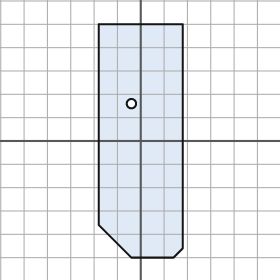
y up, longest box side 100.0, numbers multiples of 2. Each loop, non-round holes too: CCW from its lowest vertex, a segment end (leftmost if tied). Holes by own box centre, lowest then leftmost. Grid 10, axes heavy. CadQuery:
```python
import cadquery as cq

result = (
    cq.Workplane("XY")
    .moveTo(-4.0, -50.0)
    .lineTo(14.0, -50.0)
    .lineTo(18.0, -46.0)
    .lineTo(18.0, 50.0)
    .lineTo(-18.0, 50.0)
    .lineTo(-18.0, -36.0)
    .close()
    .moveTo(-4.0, 16.0)
    .circle(2.0)
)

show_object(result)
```